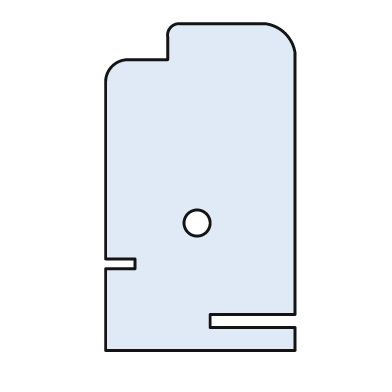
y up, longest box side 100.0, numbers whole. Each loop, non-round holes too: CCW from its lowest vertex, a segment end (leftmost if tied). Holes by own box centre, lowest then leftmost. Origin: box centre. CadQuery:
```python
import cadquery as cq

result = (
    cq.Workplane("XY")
    .moveTo(-29.0, -50.0)
    .lineTo(29.0, -50.0)
    .lineTo(29.0, -43.0)
    .lineTo(3.0, -43.0)
    .lineTo(3.0, -39.0)
    .lineTo(29.0, -39.0)
    .lineTo(29.0, 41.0)
    .threePointArc((26.0, 47.0), (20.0, 50.0))
    .lineTo(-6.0, 50.0)
    .threePointArc((-9.0, 49.0), (-10.0, 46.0))
    .lineTo(-10.0, 39.0)
    .lineTo(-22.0, 39.0)
    .threePointArc((-27.0, 37.0), (-29.0, 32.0))
    .lineTo(-29.0, -22.0)
    .lineTo(-20.0, -22.0)
    .lineTo(-20.0, -25.0)
    .lineTo(-29.0, -25.0)
    .close()
    .moveTo(-1.0, -11.0)
    .circle(4.0)
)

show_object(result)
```